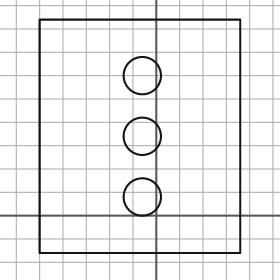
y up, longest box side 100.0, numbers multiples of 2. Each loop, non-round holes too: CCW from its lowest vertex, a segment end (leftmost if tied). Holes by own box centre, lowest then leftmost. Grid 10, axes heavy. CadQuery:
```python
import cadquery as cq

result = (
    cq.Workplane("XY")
    .moveTo(-50.0, -16.0)
    .lineTo(36.0, -16.0)
    .lineTo(36.0, 84.0)
    .lineTo(-50.0, 84.0)
    .close()
    .moveTo(-6.0, 8.0)
    .circle(8.0)
    .moveTo(-6.0, 34.0)
    .circle(8.0)
    .moveTo(-6.0, 60.0)
    .circle(8.0)
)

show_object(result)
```